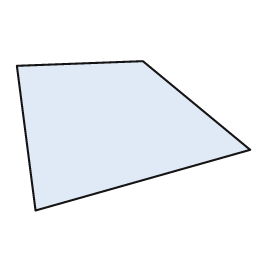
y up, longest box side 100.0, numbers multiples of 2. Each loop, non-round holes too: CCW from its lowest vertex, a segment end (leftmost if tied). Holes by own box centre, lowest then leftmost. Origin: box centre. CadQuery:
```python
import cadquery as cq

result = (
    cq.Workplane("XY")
    .moveTo(-42.0, -32.0)
    .lineTo(50.0, -6.0)
    .lineTo(4.0, 32.0)
    .lineTo(-50.0, 30.0)
    .close()
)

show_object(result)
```